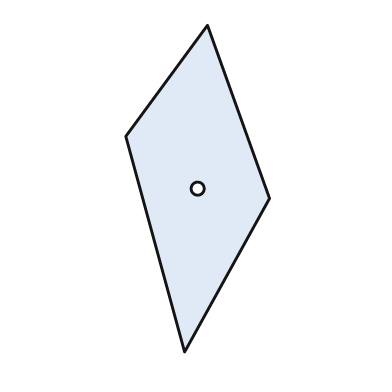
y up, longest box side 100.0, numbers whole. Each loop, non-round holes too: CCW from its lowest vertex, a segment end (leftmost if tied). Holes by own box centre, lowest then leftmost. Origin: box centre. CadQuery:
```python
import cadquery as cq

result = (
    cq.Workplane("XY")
    .moveTo(-4.0, -50.0)
    .lineTo(22.0, -3.0)
    .lineTo(3.0, 50.0)
    .lineTo(-22.0, 16.0)
    .close()
    .moveTo(0.0, 0.0)
    .circle(2.0)
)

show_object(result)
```